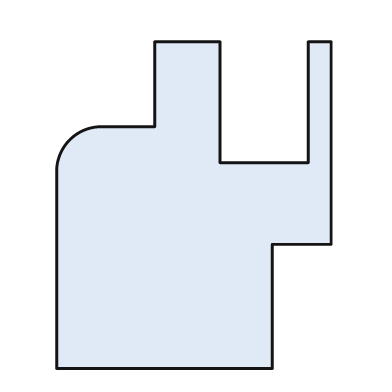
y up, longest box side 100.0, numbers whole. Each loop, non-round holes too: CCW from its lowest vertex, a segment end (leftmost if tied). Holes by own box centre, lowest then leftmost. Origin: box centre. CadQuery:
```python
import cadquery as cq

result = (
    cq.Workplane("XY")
    .moveTo(-42.0, -50.0)
    .lineTo(24.0, -50.0)
    .lineTo(24.0, -12.0)
    .lineTo(42.0, -12.0)
    .lineTo(42.0, 50.0)
    .lineTo(35.0, 50.0)
    .lineTo(35.0, 13.0)
    .lineTo(8.0, 13.0)
    .lineTo(8.0, 50.0)
    .lineTo(-12.0, 50.0)
    .lineTo(-12.0, 24.0)
    .lineTo(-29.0, 24.0)
    .threePointArc((-38.0, 20.0), (-42.0, 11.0))
    .close()
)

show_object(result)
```